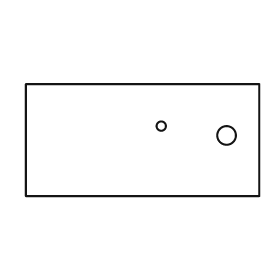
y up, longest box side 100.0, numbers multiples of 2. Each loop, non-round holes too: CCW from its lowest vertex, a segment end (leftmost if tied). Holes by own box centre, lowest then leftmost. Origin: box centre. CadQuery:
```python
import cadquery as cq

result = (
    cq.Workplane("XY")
    .moveTo(-50.0, -24.0)
    .lineTo(50.0, -24.0)
    .lineTo(50.0, 24.0)
    .lineTo(-50.0, 24.0)
    .close()
    .moveTo(36.0, 2.0)
    .circle(4.0)
    .moveTo(8.0, 6.0)
    .circle(2.0)
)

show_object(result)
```